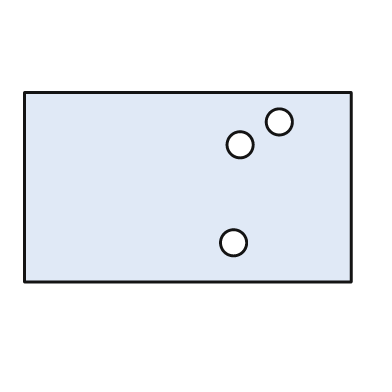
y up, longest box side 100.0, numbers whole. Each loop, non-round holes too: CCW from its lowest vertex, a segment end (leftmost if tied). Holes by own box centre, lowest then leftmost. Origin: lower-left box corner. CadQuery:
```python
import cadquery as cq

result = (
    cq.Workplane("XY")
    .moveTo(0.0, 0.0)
    .lineTo(100.0, 0.0)
    .lineTo(100.0, 58.0)
    .lineTo(0.0, 58.0)
    .close()
    .moveTo(64.0, 12.0)
    .circle(4.0)
    .moveTo(66.0, 42.0)
    .circle(4.0)
    .moveTo(78.0, 49.0)
    .circle(4.0)
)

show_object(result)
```